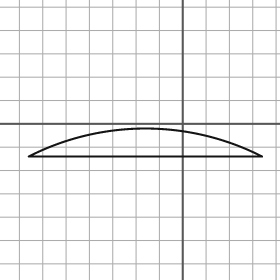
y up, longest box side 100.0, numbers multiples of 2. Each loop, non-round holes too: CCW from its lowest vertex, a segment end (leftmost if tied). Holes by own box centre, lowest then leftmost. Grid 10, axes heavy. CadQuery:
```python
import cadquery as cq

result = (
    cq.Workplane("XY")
    .moveTo(-66.0, -14.0)
    .lineTo(34.0, -14.0)
    .threePointArc((-16.0, -2.0), (-66.0, -14.0))
    .close()
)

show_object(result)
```